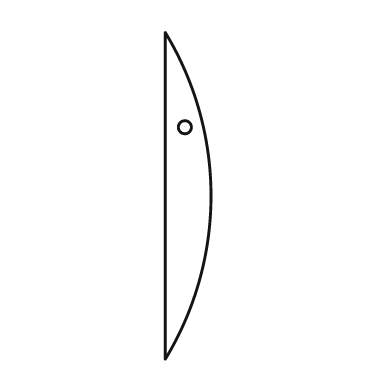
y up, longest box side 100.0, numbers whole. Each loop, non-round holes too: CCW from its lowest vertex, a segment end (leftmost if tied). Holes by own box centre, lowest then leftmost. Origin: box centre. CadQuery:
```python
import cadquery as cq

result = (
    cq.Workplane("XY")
    .moveTo(-7.0, -50.0)
    .threePointArc((7.0, 0.0), (-7.0, 50.0))
    .close()
    .moveTo(-1.0, 21.0)
    .circle(2.0)
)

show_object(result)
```